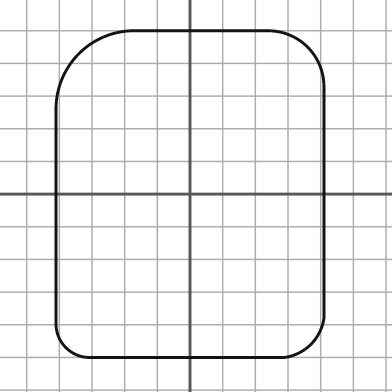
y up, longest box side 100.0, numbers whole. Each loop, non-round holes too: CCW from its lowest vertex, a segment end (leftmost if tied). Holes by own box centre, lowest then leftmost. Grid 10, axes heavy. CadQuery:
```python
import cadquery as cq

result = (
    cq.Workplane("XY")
    .moveTo(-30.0, -50.0)
    .lineTo(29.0, -50.0)
    .threePointArc((37.0, -46.0), (41.0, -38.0))
    .lineTo(41.0, 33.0)
    .threePointArc((36.0, 45.0), (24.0, 50.0))
    .lineTo(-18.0, 50.0)
    .threePointArc((-34.0, 43.0), (-41.0, 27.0))
    .lineTo(-41.0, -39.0)
    .threePointArc((-38.0, -47.0), (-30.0, -50.0))
    .close()
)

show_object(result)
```